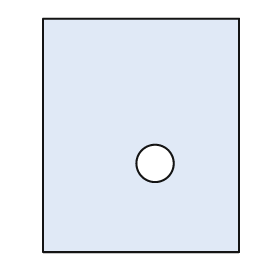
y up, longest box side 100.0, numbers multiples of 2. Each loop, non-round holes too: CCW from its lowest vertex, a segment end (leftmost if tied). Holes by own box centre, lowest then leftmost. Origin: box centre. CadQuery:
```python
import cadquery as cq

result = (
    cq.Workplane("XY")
    .moveTo(-42.0, -50.0)
    .lineTo(42.0, -50.0)
    .lineTo(42.0, 50.0)
    .lineTo(-42.0, 50.0)
    .close()
    .moveTo(6.0, -12.0)
    .circle(8.0)
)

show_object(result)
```